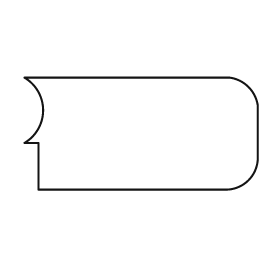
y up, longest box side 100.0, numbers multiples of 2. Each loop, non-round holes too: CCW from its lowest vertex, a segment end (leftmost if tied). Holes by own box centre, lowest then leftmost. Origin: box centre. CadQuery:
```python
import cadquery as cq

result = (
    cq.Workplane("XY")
    .moveTo(-44.0, -24.0)
    .lineTo(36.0, -24.0)
    .threePointArc((46.0, -20.0), (50.0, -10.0))
    .lineTo(50.0, 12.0)
    .threePointArc((46.0, 20.0), (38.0, 24.0))
    .lineTo(-50.0, 24.0)
    .threePointArc((-42.0, 10.0), (-50.0, -4.0))
    .lineTo(-44.0, -4.0)
    .close()
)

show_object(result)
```